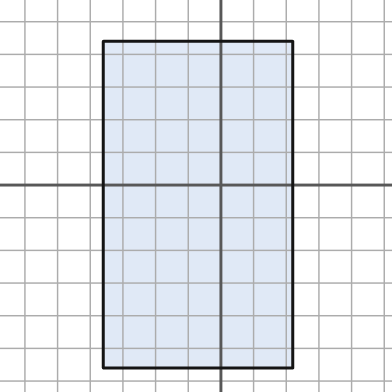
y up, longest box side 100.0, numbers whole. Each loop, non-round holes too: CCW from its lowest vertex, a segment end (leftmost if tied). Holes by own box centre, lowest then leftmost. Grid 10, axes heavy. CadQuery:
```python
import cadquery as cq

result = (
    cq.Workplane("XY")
    .moveTo(-36.0, -56.0)
    .lineTo(22.0, -56.0)
    .lineTo(22.0, 44.0)
    .lineTo(-36.0, 44.0)
    .close()
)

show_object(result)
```